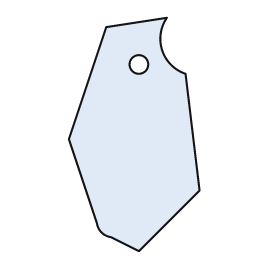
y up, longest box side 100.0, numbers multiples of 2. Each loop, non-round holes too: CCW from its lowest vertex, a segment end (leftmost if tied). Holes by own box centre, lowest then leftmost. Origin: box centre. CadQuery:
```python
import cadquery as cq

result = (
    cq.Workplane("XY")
    .moveTo(2.0, -50.0)
    .lineTo(28.0, -24.0)
    .lineTo(22.0, 26.0)
    .threePointArc((12.0, 36.0), (14.0, 50.0))
    .lineTo(-12.0, 46.0)
    .lineTo(-28.0, -2.0)
    .lineTo(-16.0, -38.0)
    .threePointArc((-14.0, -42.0), (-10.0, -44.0))
    .close()
    .moveTo(2.0, 30.0)
    .circle(4.0)
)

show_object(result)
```